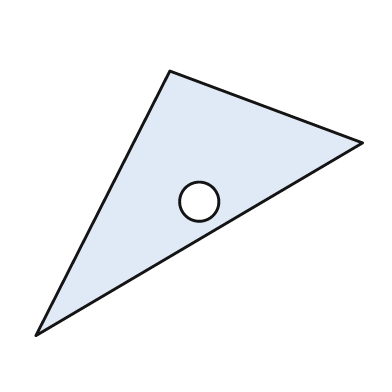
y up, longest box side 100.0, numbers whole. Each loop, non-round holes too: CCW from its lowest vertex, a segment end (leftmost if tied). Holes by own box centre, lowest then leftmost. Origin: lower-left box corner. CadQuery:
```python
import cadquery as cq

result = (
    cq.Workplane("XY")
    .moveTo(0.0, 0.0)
    .lineTo(100.0, 59.0)
    .lineTo(41.0, 81.0)
    .close()
    .moveTo(50.0, 41.0)
    .circle(6.0)
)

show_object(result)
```